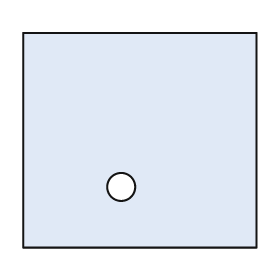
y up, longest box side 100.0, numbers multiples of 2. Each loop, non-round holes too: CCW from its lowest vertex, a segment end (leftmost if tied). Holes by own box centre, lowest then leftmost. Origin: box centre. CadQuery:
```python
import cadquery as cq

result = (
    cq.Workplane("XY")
    .moveTo(-50.0, -46.0)
    .lineTo(50.0, -46.0)
    .lineTo(50.0, 46.0)
    .lineTo(-50.0, 46.0)
    .close()
    .moveTo(-8.0, -20.0)
    .circle(6.0)
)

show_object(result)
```